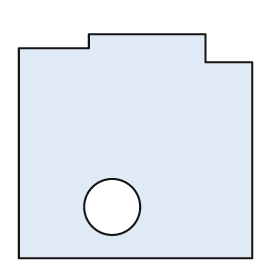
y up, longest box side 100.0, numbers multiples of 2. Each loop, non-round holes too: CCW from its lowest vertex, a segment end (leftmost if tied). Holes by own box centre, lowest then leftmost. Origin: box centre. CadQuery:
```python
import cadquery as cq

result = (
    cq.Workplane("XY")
    .moveTo(-50.0, -48.0)
    .lineTo(50.0, -48.0)
    .lineTo(50.0, 36.0)
    .lineTo(30.0, 36.0)
    .lineTo(30.0, 48.0)
    .lineTo(-20.0, 48.0)
    .lineTo(-20.0, 42.0)
    .lineTo(-50.0, 42.0)
    .close()
    .moveTo(-10.0, -26.0)
    .circle(12.0)
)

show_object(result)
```